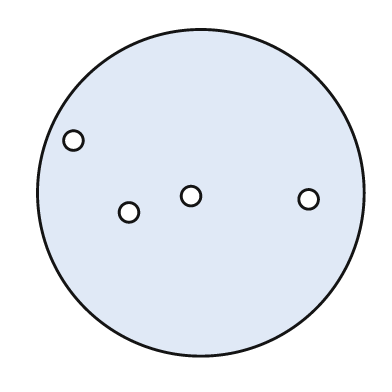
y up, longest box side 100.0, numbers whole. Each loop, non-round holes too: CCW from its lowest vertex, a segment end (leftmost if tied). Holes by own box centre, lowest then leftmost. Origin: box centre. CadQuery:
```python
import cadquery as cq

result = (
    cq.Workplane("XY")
    .moveTo(0.0, 0.0)
    .circle(50.0)
    .moveTo(-22.0, -6.0)
    .circle(3.0)
    .moveTo(33.0, -2.0)
    .circle(3.0)
    .moveTo(-3.0, -1.0)
    .circle(3.0)
    .moveTo(-39.0, 16.0)
    .circle(3.0)
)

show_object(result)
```